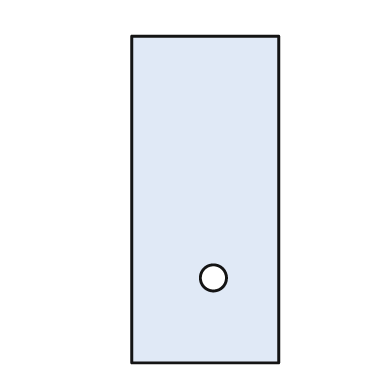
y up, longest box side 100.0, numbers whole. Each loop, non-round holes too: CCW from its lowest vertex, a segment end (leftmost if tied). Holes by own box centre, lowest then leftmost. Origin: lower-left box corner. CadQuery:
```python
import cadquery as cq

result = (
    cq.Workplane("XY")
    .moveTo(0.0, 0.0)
    .lineTo(45.0, 0.0)
    .lineTo(45.0, 100.0)
    .lineTo(0.0, 100.0)
    .close()
    .moveTo(25.0, 26.0)
    .circle(4.0)
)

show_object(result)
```